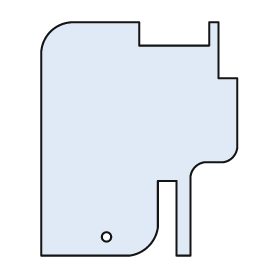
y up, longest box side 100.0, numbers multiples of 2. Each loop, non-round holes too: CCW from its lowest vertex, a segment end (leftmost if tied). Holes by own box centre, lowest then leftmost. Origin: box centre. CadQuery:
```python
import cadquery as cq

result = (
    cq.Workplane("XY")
    .moveTo(-42.0, -50.0)
    .lineTo(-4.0, -50.0)
    .threePointArc((4.0, -46.0), (8.0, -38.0))
    .lineTo(8.0, -18.0)
    .lineTo(16.0, -18.0)
    .lineTo(16.0, -50.0)
    .lineTo(22.0, -50.0)
    .lineTo(22.0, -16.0)
    .threePointArc((24.0, -12.0), (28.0, -10.0))
    .lineTo(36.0, -10.0)
    .threePointArc((40.0, -8.0), (42.0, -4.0))
    .lineTo(42.0, 26.0)
    .lineTo(34.0, 26.0)
    .lineTo(34.0, 50.0)
    .lineTo(30.0, 50.0)
    .lineTo(30.0, 40.0)
    .lineTo(0.0, 40.0)
    .lineTo(0.0, 50.0)
    .lineTo(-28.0, 50.0)
    .threePointArc((-38.0, 46.0), (-42.0, 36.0))
    .close()
    .moveTo(-14.0, -42.0)
    .circle(2.0)
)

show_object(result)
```